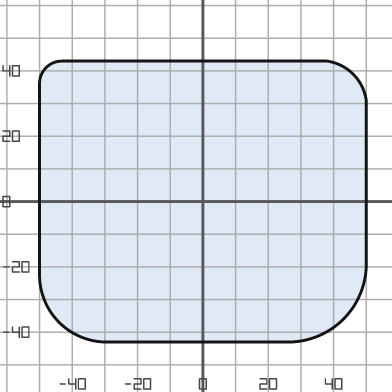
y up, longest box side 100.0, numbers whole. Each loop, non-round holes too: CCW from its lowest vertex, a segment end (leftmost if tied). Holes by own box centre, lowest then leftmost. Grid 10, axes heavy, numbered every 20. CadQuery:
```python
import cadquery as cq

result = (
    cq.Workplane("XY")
    .moveTo(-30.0, -43.0)
    .lineTo(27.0, -43.0)
    .threePointArc((43.0, -36.0), (50.0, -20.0))
    .lineTo(50.0, 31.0)
    .threePointArc((46.0, 39.0), (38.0, 43.0))
    .lineTo(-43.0, 43.0)
    .threePointArc((-48.0, 41.0), (-50.0, 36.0))
    .lineTo(-50.0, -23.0)
    .threePointArc((-44.0, -37.0), (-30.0, -43.0))
    .close()
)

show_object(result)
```